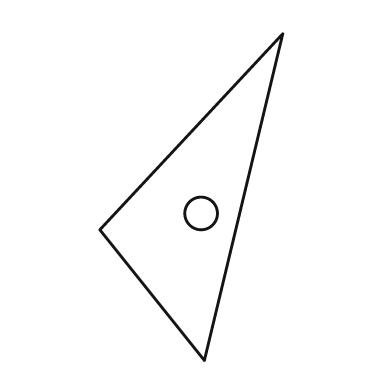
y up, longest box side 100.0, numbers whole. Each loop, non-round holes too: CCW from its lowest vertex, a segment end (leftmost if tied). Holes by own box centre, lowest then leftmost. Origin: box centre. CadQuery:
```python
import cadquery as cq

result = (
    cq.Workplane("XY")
    .moveTo(4.0, -50.0)
    .lineTo(28.0, 50.0)
    .lineTo(-28.0, -10.0)
    .close()
    .moveTo(3.0, -5.0)
    .circle(5.0)
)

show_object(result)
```